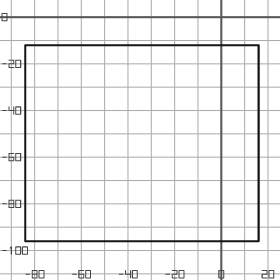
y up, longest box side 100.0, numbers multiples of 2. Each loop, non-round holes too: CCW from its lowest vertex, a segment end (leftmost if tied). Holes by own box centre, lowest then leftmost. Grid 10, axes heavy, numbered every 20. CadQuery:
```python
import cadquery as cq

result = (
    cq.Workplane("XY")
    .moveTo(-84.0, -96.0)
    .lineTo(16.0, -96.0)
    .lineTo(16.0, -12.0)
    .lineTo(-84.0, -12.0)
    .close()
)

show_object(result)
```